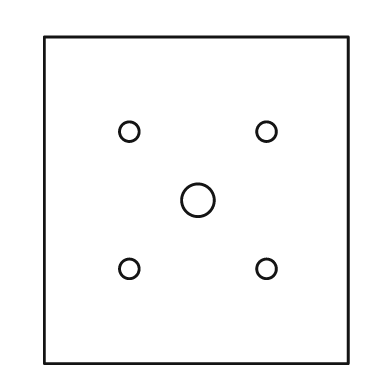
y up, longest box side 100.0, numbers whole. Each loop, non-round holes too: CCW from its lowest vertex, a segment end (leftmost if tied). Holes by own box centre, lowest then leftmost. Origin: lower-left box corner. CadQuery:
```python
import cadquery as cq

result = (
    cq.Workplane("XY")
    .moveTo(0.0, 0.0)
    .lineTo(93.0, 0.0)
    .lineTo(93.0, 100.0)
    .lineTo(0.0, 100.0)
    .close()
    .moveTo(26.0, 29.0)
    .circle(3.0)
    .moveTo(68.0, 29.0)
    .circle(3.0)
    .moveTo(47.0, 50.0)
    .circle(5.0)
    .moveTo(26.0, 71.0)
    .circle(3.0)
    .moveTo(68.0, 71.0)
    .circle(3.0)
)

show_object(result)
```